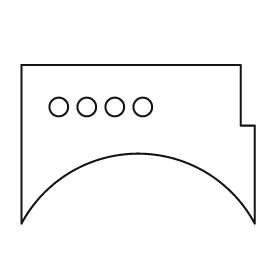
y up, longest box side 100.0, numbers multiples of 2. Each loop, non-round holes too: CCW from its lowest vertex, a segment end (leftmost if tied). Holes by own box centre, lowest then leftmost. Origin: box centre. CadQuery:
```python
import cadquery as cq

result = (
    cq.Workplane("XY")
    .moveTo(-50.0, -34.0)
    .threePointArc((0.0, -4.0), (50.0, -34.0))
    .lineTo(50.0, 8.0)
    .lineTo(44.0, 8.0)
    .lineTo(44.0, 34.0)
    .lineTo(-50.0, 34.0)
    .close()
    .moveTo(-34.0, 16.0)
    .circle(4.0)
    .moveTo(-22.0, 16.0)
    .circle(4.0)
    .moveTo(-10.0, 16.0)
    .circle(4.0)
    .moveTo(2.0, 16.0)
    .circle(4.0)
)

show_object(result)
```